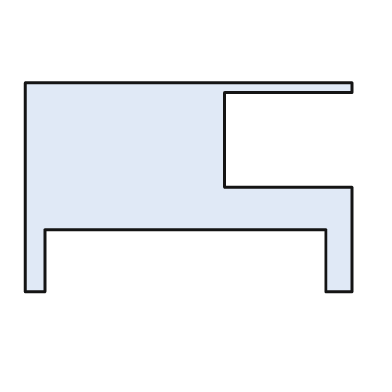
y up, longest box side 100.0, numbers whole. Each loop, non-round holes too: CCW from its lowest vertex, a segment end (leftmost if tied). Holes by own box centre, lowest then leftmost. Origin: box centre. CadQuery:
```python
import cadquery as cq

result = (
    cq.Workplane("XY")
    .moveTo(-50.0, -32.0)
    .lineTo(-44.0, -32.0)
    .lineTo(-44.0, -13.0)
    .lineTo(42.0, -13.0)
    .lineTo(42.0, -32.0)
    .lineTo(50.0, -32.0)
    .lineTo(50.0, 0.0)
    .lineTo(11.0, 0.0)
    .lineTo(11.0, 29.0)
    .lineTo(50.0, 29.0)
    .lineTo(50.0, 32.0)
    .lineTo(-50.0, 32.0)
    .close()
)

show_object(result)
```